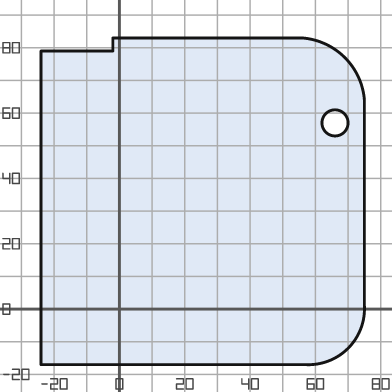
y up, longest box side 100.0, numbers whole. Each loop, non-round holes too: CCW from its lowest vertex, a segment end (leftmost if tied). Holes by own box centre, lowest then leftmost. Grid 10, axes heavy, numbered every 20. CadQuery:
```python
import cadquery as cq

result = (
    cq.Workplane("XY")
    .moveTo(-24.0, -17.0)
    .lineTo(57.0, -17.0)
    .threePointArc((70.0, -12.0), (75.0, 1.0))
    .lineTo(75.0, 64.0)
    .threePointArc((69.0, 77.0), (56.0, 83.0))
    .lineTo(-2.0, 83.0)
    .lineTo(-2.0, 79.0)
    .lineTo(-24.0, 79.0)
    .close()
    .moveTo(66.0, 57.0)
    .circle(4.0)
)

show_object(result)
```